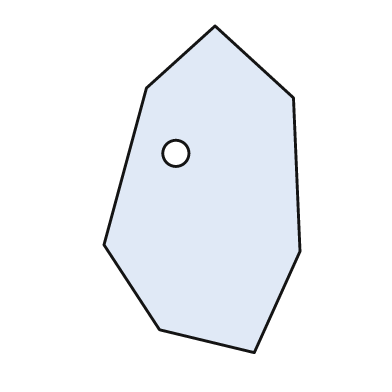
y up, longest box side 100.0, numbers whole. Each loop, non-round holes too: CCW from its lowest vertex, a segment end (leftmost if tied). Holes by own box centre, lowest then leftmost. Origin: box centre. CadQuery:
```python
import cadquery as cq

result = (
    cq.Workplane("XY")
    .moveTo(16.0, -50.0)
    .lineTo(30.0, -19.0)
    .lineTo(28.0, 28.0)
    .lineTo(4.0, 50.0)
    .lineTo(-17.0, 31.0)
    .lineTo(-30.0, -17.0)
    .lineTo(-13.0, -43.0)
    .close()
    .moveTo(-8.0, 11.0)
    .circle(4.0)
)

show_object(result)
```